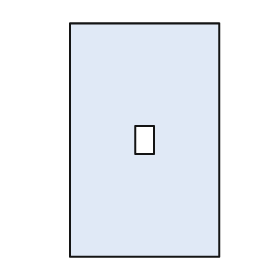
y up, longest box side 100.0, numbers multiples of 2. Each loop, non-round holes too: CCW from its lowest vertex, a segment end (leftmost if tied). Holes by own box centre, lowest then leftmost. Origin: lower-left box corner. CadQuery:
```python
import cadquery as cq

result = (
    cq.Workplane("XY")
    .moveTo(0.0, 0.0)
    .lineTo(64.0, 0.0)
    .lineTo(64.0, 100.0)
    .lineTo(0.0, 100.0)
    .close()
    .moveTo(28.0, 44.0)
    .lineTo(36.0, 44.0)
    .lineTo(36.0, 56.0)
    .lineTo(28.0, 56.0)
    .close()
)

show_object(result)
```